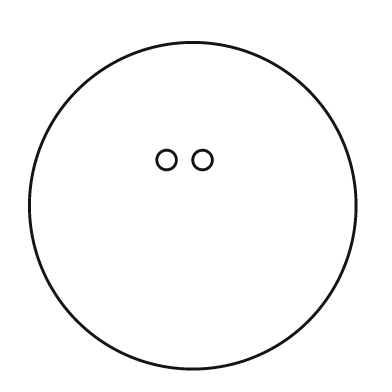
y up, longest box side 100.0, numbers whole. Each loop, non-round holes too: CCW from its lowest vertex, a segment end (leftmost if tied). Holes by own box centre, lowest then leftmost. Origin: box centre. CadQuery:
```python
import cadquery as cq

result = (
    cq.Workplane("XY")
    .moveTo(0.0, 0.0)
    .circle(50.0)
    .moveTo(-8.0, 14.0)
    .circle(3.0)
    .moveTo(3.0, 14.0)
    .circle(3.0)
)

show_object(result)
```